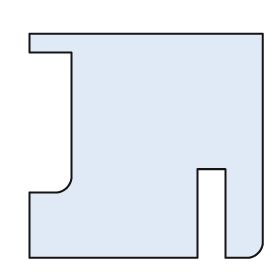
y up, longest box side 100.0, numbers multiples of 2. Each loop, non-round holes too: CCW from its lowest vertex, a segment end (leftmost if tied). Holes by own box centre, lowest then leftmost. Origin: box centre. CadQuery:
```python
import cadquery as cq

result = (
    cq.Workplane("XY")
    .moveTo(-50.0, -48.0)
    .lineTo(22.0, -48.0)
    .lineTo(22.0, -10.0)
    .lineTo(34.0, -10.0)
    .lineTo(34.0, -48.0)
    .lineTo(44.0, -48.0)
    .threePointArc((48.0, -46.0), (50.0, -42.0))
    .lineTo(50.0, 48.0)
    .lineTo(-50.0, 48.0)
    .lineTo(-50.0, 40.0)
    .lineTo(-32.0, 40.0)
    .lineTo(-32.0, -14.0)
    .threePointArc((-34.0, -18.0), (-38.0, -20.0))
    .lineTo(-50.0, -20.0)
    .close()
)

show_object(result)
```